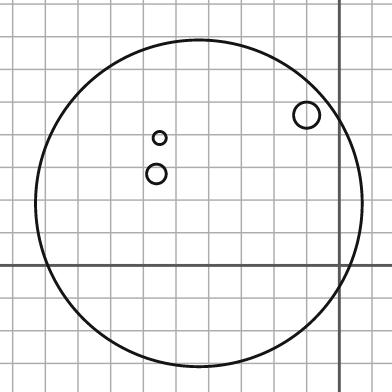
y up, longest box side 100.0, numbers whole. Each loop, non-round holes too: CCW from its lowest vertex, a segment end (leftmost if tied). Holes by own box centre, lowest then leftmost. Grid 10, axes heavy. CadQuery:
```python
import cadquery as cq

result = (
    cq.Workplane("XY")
    .moveTo(-43.0, 19.0)
    .circle(50.0)
    .moveTo(-56.0, 28.0)
    .circle(3.0)
    .moveTo(-55.0, 39.0)
    .circle(2.0)
    .moveTo(-10.0, 46.0)
    .circle(4.0)
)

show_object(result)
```